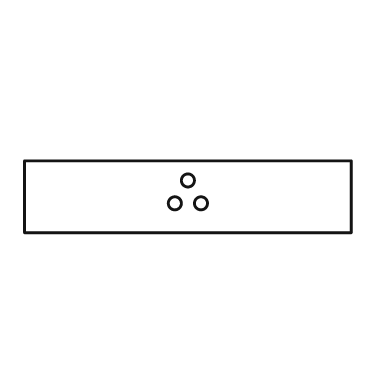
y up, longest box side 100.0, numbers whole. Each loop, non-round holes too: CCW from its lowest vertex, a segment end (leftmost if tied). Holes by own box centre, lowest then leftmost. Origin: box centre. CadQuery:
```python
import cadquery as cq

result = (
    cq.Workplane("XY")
    .moveTo(-50.0, -11.0)
    .lineTo(50.0, -11.0)
    .lineTo(50.0, 11.0)
    .lineTo(-50.0, 11.0)
    .close()
    .moveTo(-4.0, -2.0)
    .circle(2.0)
    .moveTo(4.0, -2.0)
    .circle(2.0)
    .moveTo(0.0, 5.0)
    .circle(2.0)
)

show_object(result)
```